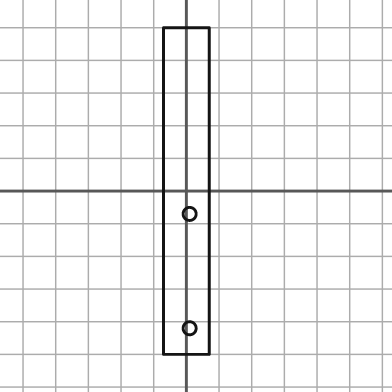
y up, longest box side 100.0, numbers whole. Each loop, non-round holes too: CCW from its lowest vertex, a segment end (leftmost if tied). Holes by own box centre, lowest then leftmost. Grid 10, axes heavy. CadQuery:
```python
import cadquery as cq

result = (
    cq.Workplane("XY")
    .moveTo(-7.0, -50.0)
    .lineTo(7.0, -50.0)
    .lineTo(7.0, 50.0)
    .lineTo(-7.0, 50.0)
    .close()
    .moveTo(1.0, -42.0)
    .circle(2.0)
    .moveTo(1.0, -7.0)
    .circle(2.0)
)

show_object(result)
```